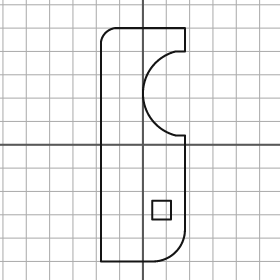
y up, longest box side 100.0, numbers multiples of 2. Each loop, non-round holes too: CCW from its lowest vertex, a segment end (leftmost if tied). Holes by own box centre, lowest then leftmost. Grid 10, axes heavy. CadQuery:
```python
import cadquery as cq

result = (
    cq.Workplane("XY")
    .moveTo(-18.0, -50.0)
    .lineTo(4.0, -50.0)
    .threePointArc((14.0, -46.0), (18.0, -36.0))
    .lineTo(18.0, 4.0)
    .lineTo(14.0, 4.0)
    .threePointArc((0.0, 22.0), (14.0, 40.0))
    .lineTo(18.0, 40.0)
    .lineTo(18.0, 50.0)
    .lineTo(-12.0, 50.0)
    .threePointArc((-16.0, 48.0), (-18.0, 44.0))
    .close()
    .moveTo(4.0, -32.0)
    .lineTo(12.0, -32.0)
    .lineTo(12.0, -24.0)
    .lineTo(4.0, -24.0)
    .close()
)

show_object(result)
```